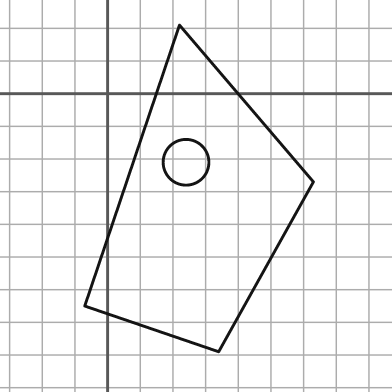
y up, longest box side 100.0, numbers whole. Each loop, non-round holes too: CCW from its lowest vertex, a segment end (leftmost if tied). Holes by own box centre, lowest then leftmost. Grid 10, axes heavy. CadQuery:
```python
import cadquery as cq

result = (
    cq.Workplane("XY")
    .moveTo(34.0, -79.0)
    .lineTo(63.0, -27.0)
    .lineTo(22.0, 21.0)
    .lineTo(-7.0, -65.0)
    .close()
    .moveTo(24.0, -21.0)
    .circle(7.0)
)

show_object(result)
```